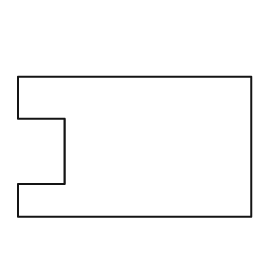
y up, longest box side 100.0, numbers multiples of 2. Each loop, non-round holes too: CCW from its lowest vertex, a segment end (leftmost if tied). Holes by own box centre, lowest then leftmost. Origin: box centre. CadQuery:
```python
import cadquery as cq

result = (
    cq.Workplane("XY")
    .moveTo(-50.0, -30.0)
    .lineTo(50.0, -30.0)
    .lineTo(50.0, 30.0)
    .lineTo(-50.0, 30.0)
    .lineTo(-50.0, 12.0)
    .lineTo(-30.0, 12.0)
    .lineTo(-30.0, -16.0)
    .lineTo(-50.0, -16.0)
    .close()
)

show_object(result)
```